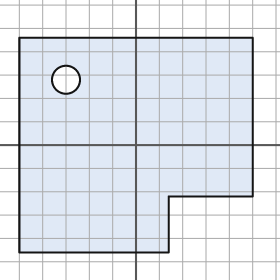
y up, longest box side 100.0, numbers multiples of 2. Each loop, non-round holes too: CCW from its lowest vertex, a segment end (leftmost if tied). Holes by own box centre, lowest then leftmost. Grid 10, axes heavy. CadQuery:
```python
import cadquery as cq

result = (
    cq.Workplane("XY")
    .moveTo(-50.0, -46.0)
    .lineTo(14.0, -46.0)
    .lineTo(14.0, -22.0)
    .lineTo(50.0, -22.0)
    .lineTo(50.0, 46.0)
    .lineTo(-50.0, 46.0)
    .close()
    .moveTo(-30.0, 28.0)
    .circle(6.0)
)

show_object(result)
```